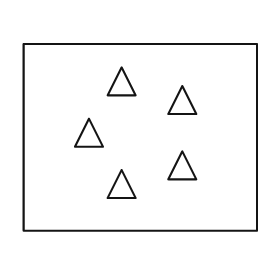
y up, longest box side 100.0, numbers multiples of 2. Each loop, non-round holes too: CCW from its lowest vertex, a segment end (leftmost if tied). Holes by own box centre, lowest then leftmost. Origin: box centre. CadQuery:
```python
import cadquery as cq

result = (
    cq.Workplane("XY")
    .moveTo(-50.0, -40.0)
    .lineTo(50.0, -40.0)
    .lineTo(50.0, 40.0)
    .lineTo(-50.0, 40.0)
    .close()
    .moveTo(-14.0, -26.0)
    .lineTo(-2.0, -26.0)
    .lineTo(-8.0, -14.0)
    .close()
    .moveTo(12.0, -18.0)
    .lineTo(24.0, -18.0)
    .lineTo(18.0, -6.0)
    .close()
    .moveTo(-28.0, -4.0)
    .lineTo(-16.0, -4.0)
    .lineTo(-22.0, 8.0)
    .close()
    .moveTo(12.0, 10.0)
    .lineTo(24.0, 10.0)
    .lineTo(18.0, 22.0)
    .close()
    .moveTo(-14.0, 18.0)
    .lineTo(-2.0, 18.0)
    .lineTo(-8.0, 30.0)
    .close()
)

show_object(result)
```